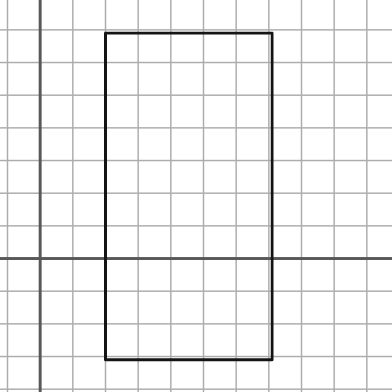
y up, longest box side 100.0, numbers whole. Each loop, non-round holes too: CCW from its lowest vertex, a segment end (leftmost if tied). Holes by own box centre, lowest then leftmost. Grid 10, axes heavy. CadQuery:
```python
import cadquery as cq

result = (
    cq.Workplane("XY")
    .moveTo(20.0, -31.0)
    .lineTo(71.0, -31.0)
    .lineTo(71.0, 69.0)
    .lineTo(20.0, 69.0)
    .close()
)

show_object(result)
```